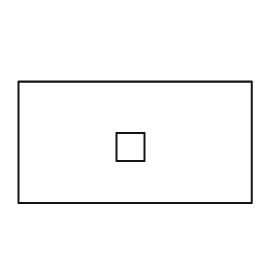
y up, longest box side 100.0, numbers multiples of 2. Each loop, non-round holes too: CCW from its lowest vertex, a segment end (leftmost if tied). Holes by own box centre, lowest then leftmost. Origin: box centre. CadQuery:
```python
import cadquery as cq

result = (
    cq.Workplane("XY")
    .moveTo(-50.0, -26.0)
    .lineTo(50.0, -26.0)
    .lineTo(50.0, 26.0)
    .lineTo(-50.0, 26.0)
    .close()
    .moveTo(-8.0, -8.0)
    .lineTo(4.0, -8.0)
    .lineTo(4.0, 4.0)
    .lineTo(-8.0, 4.0)
    .close()
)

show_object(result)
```